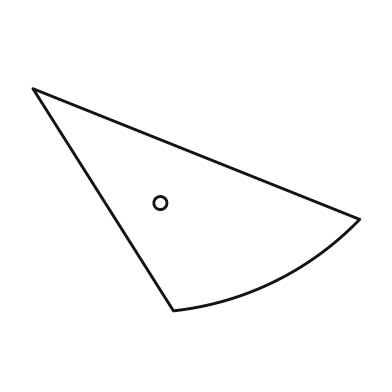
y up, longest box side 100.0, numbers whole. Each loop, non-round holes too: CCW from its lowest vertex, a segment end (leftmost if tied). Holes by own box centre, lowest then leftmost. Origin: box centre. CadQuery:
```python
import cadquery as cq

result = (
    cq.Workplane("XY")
    .moveTo(-7.0, -34.0)
    .threePointArc((24.0, -25.0), (50.0, -6.0))
    .lineTo(-50.0, 34.0)
    .close()
    .moveTo(-11.0, -1.0)
    .circle(2.0)
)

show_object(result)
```